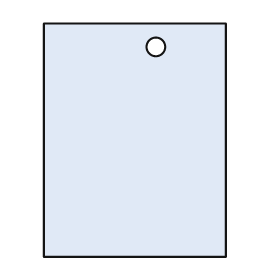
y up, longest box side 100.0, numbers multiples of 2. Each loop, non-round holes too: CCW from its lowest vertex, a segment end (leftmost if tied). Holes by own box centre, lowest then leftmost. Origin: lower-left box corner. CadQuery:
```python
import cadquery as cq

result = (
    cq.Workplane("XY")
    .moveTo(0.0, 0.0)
    .lineTo(78.0, 0.0)
    .lineTo(78.0, 100.0)
    .lineTo(0.0, 100.0)
    .close()
    .moveTo(48.0, 90.0)
    .circle(4.0)
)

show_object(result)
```